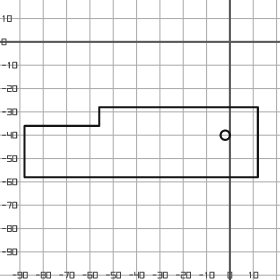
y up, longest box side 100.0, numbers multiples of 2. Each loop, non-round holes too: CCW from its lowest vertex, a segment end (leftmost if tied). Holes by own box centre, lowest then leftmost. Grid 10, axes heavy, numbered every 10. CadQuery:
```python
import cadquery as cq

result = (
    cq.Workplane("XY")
    .moveTo(-88.0, -58.0)
    .lineTo(12.0, -58.0)
    .lineTo(12.0, -28.0)
    .lineTo(-56.0, -28.0)
    .lineTo(-56.0, -36.0)
    .lineTo(-88.0, -36.0)
    .close()
    .moveTo(-2.0, -40.0)
    .circle(2.0)
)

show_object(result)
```